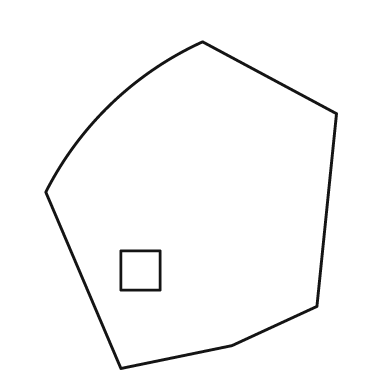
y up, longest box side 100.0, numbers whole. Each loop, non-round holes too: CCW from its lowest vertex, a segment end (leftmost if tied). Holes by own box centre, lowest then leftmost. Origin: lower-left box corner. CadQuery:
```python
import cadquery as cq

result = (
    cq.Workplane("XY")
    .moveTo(23.0, 0.0)
    .lineTo(57.0, 7.0)
    .lineTo(83.0, 19.0)
    .lineTo(89.0, 78.0)
    .lineTo(48.0, 100.0)
    .threePointArc((20.0, 81.0), (0.0, 54.0))
    .close()
    .moveTo(23.0, 24.0)
    .lineTo(35.0, 24.0)
    .lineTo(35.0, 36.0)
    .lineTo(23.0, 36.0)
    .close()
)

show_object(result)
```